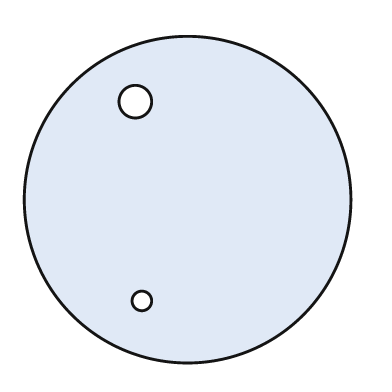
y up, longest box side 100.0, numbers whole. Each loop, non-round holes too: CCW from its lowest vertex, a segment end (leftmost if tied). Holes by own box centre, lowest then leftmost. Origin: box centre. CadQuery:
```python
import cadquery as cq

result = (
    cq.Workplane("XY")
    .moveTo(0.0, 0.0)
    .circle(50.0)
    .moveTo(-14.0, -31.0)
    .circle(3.0)
    .moveTo(-16.0, 30.0)
    .circle(5.0)
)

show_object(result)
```